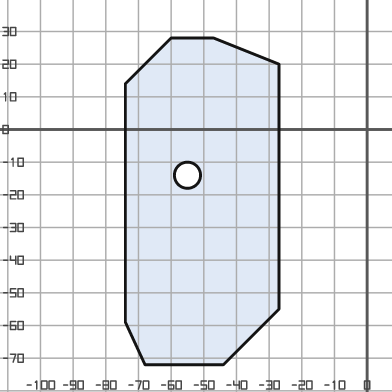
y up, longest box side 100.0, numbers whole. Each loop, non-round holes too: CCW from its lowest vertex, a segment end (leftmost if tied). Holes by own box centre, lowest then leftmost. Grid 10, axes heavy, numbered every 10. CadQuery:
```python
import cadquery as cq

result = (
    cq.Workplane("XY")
    .moveTo(-68.0, -72.0)
    .lineTo(-44.0, -72.0)
    .lineTo(-27.0, -55.0)
    .lineTo(-27.0, 20.0)
    .lineTo(-47.0, 28.0)
    .lineTo(-60.0, 28.0)
    .lineTo(-74.0, 14.0)
    .lineTo(-74.0, -59.0)
    .close()
    .moveTo(-55.0, -14.0)
    .circle(4.0)
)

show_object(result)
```